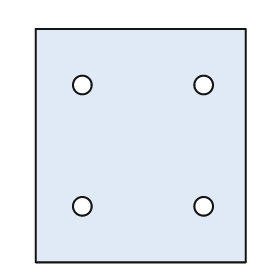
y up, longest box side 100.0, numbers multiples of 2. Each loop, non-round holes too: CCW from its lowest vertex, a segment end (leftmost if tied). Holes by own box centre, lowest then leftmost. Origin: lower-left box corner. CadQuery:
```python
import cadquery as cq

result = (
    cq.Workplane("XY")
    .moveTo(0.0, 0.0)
    .lineTo(90.0, 0.0)
    .lineTo(90.0, 100.0)
    .lineTo(0.0, 100.0)
    .close()
    .moveTo(20.0, 24.0)
    .circle(4.0)
    .moveTo(72.0, 24.0)
    .circle(4.0)
    .moveTo(20.0, 76.0)
    .circle(4.0)
    .moveTo(72.0, 76.0)
    .circle(4.0)
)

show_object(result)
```